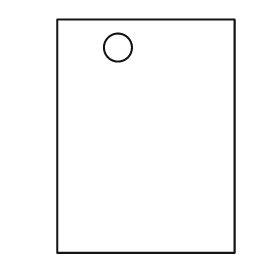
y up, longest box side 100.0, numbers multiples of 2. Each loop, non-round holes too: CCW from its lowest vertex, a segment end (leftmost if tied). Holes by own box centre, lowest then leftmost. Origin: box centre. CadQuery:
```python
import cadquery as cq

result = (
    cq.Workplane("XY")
    .moveTo(-38.0, -50.0)
    .lineTo(38.0, -50.0)
    .lineTo(38.0, 50.0)
    .lineTo(-38.0, 50.0)
    .close()
    .moveTo(-12.0, 38.0)
    .circle(6.0)
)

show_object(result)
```